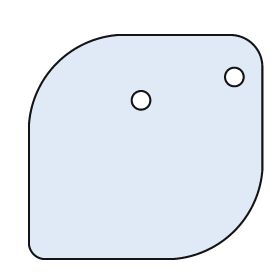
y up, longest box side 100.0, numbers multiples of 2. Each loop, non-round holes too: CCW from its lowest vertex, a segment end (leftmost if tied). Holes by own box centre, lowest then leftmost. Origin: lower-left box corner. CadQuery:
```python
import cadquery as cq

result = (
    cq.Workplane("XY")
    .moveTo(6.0, 0.0)
    .lineTo(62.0, 0.0)
    .threePointArc((88.0, 12.0), (100.0, 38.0))
    .lineTo(100.0, 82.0)
    .threePointArc((96.0, 92.0), (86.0, 96.0))
    .lineTo(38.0, 96.0)
    .threePointArc((12.0, 84.0), (0.0, 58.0))
    .lineTo(0.0, 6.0)
    .threePointArc((2.0, 2.0), (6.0, 0.0))
    .close()
    .moveTo(48.0, 68.0)
    .circle(4.0)
    .moveTo(88.0, 78.0)
    .circle(4.0)
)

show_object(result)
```